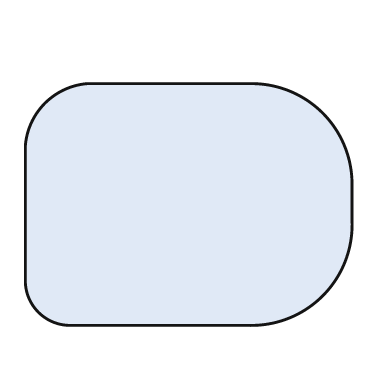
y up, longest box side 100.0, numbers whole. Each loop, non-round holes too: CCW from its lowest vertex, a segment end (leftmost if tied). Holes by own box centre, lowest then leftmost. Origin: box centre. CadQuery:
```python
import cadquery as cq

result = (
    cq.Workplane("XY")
    .moveTo(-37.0, -37.0)
    .lineTo(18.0, -37.0)
    .threePointArc((41.0, -28.0), (50.0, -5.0))
    .lineTo(50.0, 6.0)
    .threePointArc((41.0, 28.0), (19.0, 37.0))
    .lineTo(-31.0, 37.0)
    .threePointArc((-44.0, 31.0), (-50.0, 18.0))
    .lineTo(-50.0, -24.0)
    .threePointArc((-46.0, -33.0), (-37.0, -37.0))
    .close()
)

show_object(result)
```